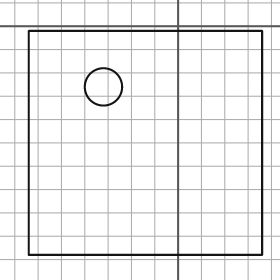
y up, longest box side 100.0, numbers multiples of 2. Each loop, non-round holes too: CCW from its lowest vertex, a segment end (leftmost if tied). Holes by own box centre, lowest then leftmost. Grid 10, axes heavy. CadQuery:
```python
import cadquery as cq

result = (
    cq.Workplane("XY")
    .moveTo(-64.0, -98.0)
    .lineTo(36.0, -98.0)
    .lineTo(36.0, -2.0)
    .lineTo(-64.0, -2.0)
    .close()
    .moveTo(-32.0, -26.0)
    .circle(8.0)
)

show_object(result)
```